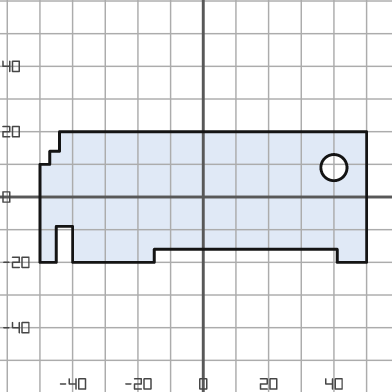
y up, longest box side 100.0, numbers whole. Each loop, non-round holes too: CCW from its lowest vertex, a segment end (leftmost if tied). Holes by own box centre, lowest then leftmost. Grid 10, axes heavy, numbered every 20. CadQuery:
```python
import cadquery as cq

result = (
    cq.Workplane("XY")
    .moveTo(-50.0, -20.0)
    .lineTo(-45.0, -20.0)
    .lineTo(-45.0, -9.0)
    .lineTo(-40.0, -9.0)
    .lineTo(-40.0, -20.0)
    .lineTo(-15.0, -20.0)
    .lineTo(-15.0, -16.0)
    .lineTo(41.0, -16.0)
    .lineTo(41.0, -20.0)
    .lineTo(50.0, -20.0)
    .lineTo(50.0, 20.0)
    .lineTo(-44.0, 20.0)
    .lineTo(-44.0, 14.0)
    .lineTo(-47.0, 14.0)
    .lineTo(-47.0, 10.0)
    .lineTo(-50.0, 10.0)
    .close()
    .moveTo(40.0, 9.0)
    .circle(4.0)
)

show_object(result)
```